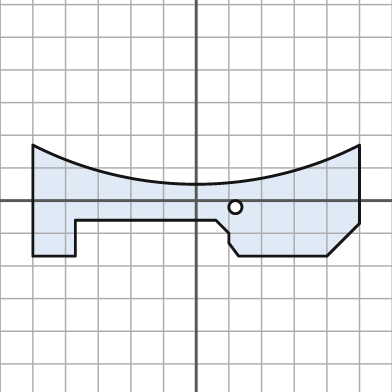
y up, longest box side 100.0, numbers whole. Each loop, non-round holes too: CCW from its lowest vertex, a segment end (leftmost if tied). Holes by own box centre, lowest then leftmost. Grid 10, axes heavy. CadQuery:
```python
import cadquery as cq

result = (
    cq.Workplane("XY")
    .moveTo(-50.0, -17.0)
    .lineTo(-37.0, -17.0)
    .lineTo(-37.0, -6.0)
    .lineTo(6.0, -6.0)
    .lineTo(10.0, -10.0)
    .lineTo(10.0, -13.0)
    .lineTo(13.0, -17.0)
    .lineTo(40.0, -17.0)
    .lineTo(50.0, -7.0)
    .lineTo(50.0, 17.0)
    .threePointArc((0.0, 5.0), (-50.0, 17.0))
    .close()
    .moveTo(12.0, -2.0)
    .circle(2.0)
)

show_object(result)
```